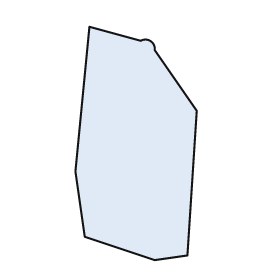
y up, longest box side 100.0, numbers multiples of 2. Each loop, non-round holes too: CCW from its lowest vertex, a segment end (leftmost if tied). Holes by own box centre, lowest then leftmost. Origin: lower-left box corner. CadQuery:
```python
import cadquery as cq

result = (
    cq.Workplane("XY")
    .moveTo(34.0, 0.0)
    .lineTo(48.0, 2.0)
    .lineTo(52.0, 64.0)
    .lineTo(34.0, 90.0)
    .threePointArc((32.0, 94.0), (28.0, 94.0))
    .lineTo(6.0, 100.0)
    .lineTo(0.0, 38.0)
    .lineTo(4.0, 10.0)
    .close()
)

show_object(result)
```